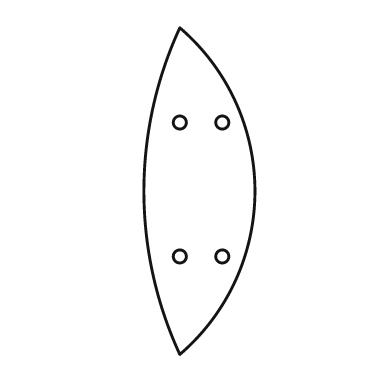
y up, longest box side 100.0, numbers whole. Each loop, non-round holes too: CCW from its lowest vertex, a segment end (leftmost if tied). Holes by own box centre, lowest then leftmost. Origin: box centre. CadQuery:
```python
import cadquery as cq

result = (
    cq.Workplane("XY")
    .moveTo(-6.0, -50.0)
    .threePointArc((17.0, 0.0), (-6.0, 50.0))
    .threePointArc((-17.0, 0.0), (-6.0, -50.0))
    .close()
    .moveTo(-6.0, -20.0)
    .circle(2.0)
    .moveTo(7.0, -20.0)
    .circle(2.0)
    .moveTo(-6.0, 21.0)
    .circle(2.0)
    .moveTo(7.0, 21.0)
    .circle(2.0)
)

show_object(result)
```